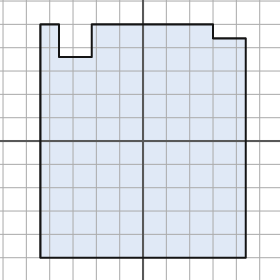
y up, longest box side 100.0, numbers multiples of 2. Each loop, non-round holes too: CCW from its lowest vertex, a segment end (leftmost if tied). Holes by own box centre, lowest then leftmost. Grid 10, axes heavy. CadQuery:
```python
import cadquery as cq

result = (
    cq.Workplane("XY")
    .moveTo(-44.0, -50.0)
    .lineTo(44.0, -50.0)
    .lineTo(44.0, 44.0)
    .lineTo(30.0, 44.0)
    .lineTo(30.0, 50.0)
    .lineTo(-22.0, 50.0)
    .lineTo(-22.0, 36.0)
    .lineTo(-36.0, 36.0)
    .lineTo(-36.0, 50.0)
    .lineTo(-44.0, 50.0)
    .close()
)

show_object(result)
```